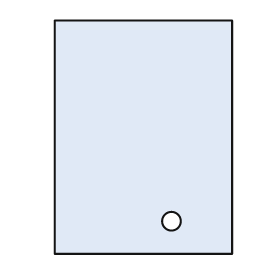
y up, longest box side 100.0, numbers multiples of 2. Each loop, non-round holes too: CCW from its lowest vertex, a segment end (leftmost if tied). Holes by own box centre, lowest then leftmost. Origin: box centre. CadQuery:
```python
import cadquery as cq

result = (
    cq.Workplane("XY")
    .moveTo(-38.0, -50.0)
    .lineTo(38.0, -50.0)
    .lineTo(38.0, 50.0)
    .lineTo(-38.0, 50.0)
    .close()
    .moveTo(12.0, -36.0)
    .circle(4.0)
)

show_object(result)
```